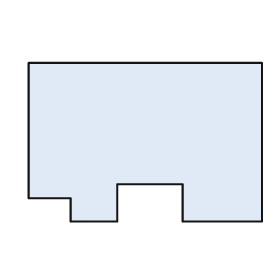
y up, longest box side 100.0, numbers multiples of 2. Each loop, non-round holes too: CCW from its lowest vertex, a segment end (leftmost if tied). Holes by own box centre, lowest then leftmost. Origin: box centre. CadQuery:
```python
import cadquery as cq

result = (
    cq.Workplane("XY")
    .moveTo(-32.0, -34.0)
    .lineTo(-12.0, -34.0)
    .lineTo(-12.0, -18.0)
    .lineTo(16.0, -18.0)
    .lineTo(16.0, -34.0)
    .lineTo(50.0, -34.0)
    .lineTo(50.0, 34.0)
    .lineTo(-50.0, 34.0)
    .lineTo(-50.0, -24.0)
    .lineTo(-32.0, -24.0)
    .close()
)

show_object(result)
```